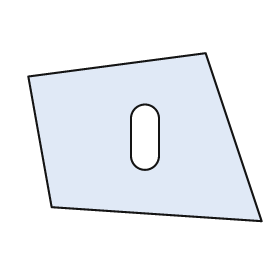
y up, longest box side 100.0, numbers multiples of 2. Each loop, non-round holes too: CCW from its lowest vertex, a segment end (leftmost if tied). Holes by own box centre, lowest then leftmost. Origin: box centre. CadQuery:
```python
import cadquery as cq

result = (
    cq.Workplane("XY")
    .moveTo(50.0, -36.0)
    .lineTo(26.0, 36.0)
    .lineTo(-50.0, 26.0)
    .lineTo(-40.0, -30.0)
    .close()
    .moveTo(-6.0, -8.0)
    .threePointArc((0.0, -14.0), (6.0, -8.0))
    .lineTo(6.0, 8.0)
    .threePointArc((0.0, 14.0), (-6.0, 8.0))
    .close()
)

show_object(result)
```